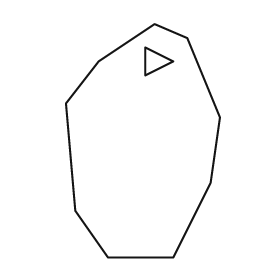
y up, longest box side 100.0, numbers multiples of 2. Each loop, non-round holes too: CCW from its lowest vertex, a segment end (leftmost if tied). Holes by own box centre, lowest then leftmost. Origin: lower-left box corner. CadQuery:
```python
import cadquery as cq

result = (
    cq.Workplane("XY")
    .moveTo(18.0, 0.0)
    .lineTo(46.0, 0.0)
    .lineTo(62.0, 32.0)
    .lineTo(66.0, 60.0)
    .lineTo(52.0, 94.0)
    .lineTo(38.0, 100.0)
    .lineTo(14.0, 84.0)
    .lineTo(0.0, 66.0)
    .lineTo(4.0, 20.0)
    .close()
    .moveTo(34.0, 78.0)
    .lineTo(46.0, 84.0)
    .lineTo(34.0, 90.0)
    .close()
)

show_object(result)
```